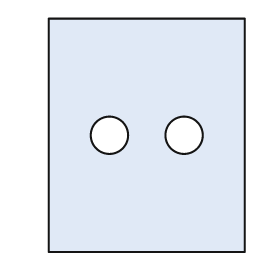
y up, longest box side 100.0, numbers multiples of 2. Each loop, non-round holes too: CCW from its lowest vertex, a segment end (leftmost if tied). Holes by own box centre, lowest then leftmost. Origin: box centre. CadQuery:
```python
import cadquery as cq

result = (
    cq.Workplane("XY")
    .moveTo(-42.0, -50.0)
    .lineTo(42.0, -50.0)
    .lineTo(42.0, 50.0)
    .lineTo(-42.0, 50.0)
    .close()
    .moveTo(-16.0, 0.0)
    .circle(8.0)
    .moveTo(16.0, 0.0)
    .circle(8.0)
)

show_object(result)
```